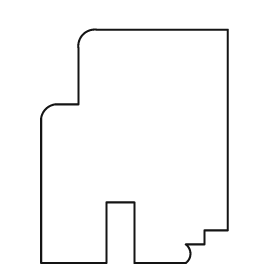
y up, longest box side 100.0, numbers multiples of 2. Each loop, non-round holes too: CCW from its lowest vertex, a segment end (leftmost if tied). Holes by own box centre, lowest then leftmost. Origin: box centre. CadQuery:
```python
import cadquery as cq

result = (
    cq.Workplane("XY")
    .moveTo(-40.0, -50.0)
    .lineTo(-12.0, -50.0)
    .lineTo(-12.0, -24.0)
    .lineTo(0.0, -24.0)
    .lineTo(0.0, -50.0)
    .lineTo(22.0, -50.0)
    .threePointArc((24.0, -46.0), (22.0, -42.0))
    .lineTo(30.0, -42.0)
    .lineTo(30.0, -36.0)
    .lineTo(40.0, -36.0)
    .lineTo(40.0, 50.0)
    .lineTo(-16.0, 50.0)
    .threePointArc((-22.0, 48.0), (-24.0, 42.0))
    .lineTo(-24.0, 18.0)
    .lineTo(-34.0, 18.0)
    .threePointArc((-38.0, 16.0), (-40.0, 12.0))
    .close()
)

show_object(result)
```